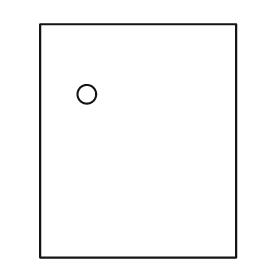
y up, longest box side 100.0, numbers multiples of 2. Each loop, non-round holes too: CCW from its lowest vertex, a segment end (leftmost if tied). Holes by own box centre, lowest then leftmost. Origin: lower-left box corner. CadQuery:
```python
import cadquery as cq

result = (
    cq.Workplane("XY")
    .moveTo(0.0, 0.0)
    .lineTo(84.0, 0.0)
    .lineTo(84.0, 100.0)
    .lineTo(0.0, 100.0)
    .close()
    .moveTo(20.0, 70.0)
    .circle(4.0)
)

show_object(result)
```